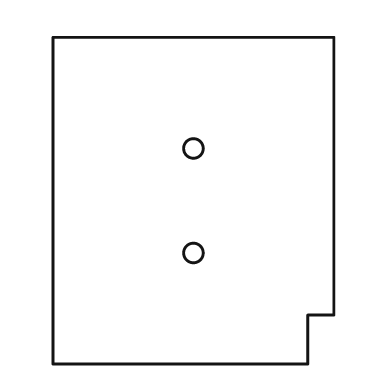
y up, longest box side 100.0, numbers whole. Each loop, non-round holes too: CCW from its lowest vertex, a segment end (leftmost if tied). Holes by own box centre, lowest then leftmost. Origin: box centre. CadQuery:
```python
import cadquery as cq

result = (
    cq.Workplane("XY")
    .moveTo(-43.0, -50.0)
    .lineTo(35.0, -50.0)
    .lineTo(35.0, -35.0)
    .lineTo(43.0, -35.0)
    .lineTo(43.0, 50.0)
    .lineTo(-43.0, 50.0)
    .close()
    .moveTo(0.0, -16.0)
    .circle(3.0)
    .moveTo(0.0, 16.0)
    .circle(3.0)
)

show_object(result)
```